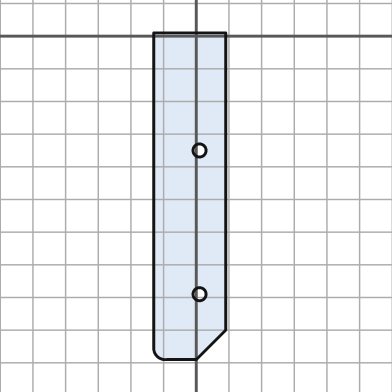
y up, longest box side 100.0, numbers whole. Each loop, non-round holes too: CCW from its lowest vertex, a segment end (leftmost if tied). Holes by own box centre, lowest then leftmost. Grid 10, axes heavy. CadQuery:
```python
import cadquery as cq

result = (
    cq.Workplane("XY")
    .moveTo(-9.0, -99.0)
    .lineTo(0.0, -99.0)
    .lineTo(9.0, -90.0)
    .lineTo(9.0, 1.0)
    .lineTo(-13.0, 1.0)
    .lineTo(-13.0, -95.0)
    .threePointArc((-12.0, -98.0), (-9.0, -99.0))
    .close()
    .moveTo(1.0, -79.0)
    .circle(2.0)
    .moveTo(1.0, -35.0)
    .circle(2.0)
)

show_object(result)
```